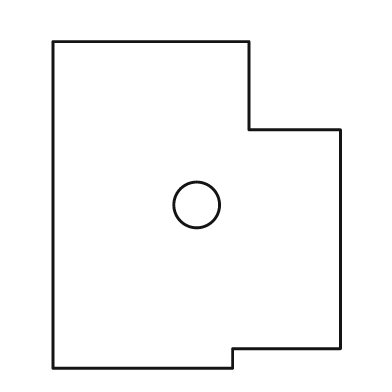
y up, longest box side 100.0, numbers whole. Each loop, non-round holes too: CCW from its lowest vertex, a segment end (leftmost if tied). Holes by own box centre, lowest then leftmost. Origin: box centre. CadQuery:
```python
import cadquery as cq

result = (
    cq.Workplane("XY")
    .moveTo(-44.0, -50.0)
    .lineTo(11.0, -50.0)
    .lineTo(11.0, -44.0)
    .lineTo(44.0, -44.0)
    .lineTo(44.0, 23.0)
    .lineTo(16.0, 23.0)
    .lineTo(16.0, 50.0)
    .lineTo(-44.0, 50.0)
    .close()
    .moveTo(0.0, 0.0)
    .circle(7.0)
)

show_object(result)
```